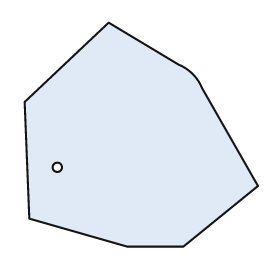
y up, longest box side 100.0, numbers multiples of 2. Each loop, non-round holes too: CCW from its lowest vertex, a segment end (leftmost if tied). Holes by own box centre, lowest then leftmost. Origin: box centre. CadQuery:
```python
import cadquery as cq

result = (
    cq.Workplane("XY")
    .moveTo(-6.0, -48.0)
    .lineTo(18.0, -48.0)
    .lineTo(50.0, -22.0)
    .lineTo(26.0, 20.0)
    .threePointArc((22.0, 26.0), (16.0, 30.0))
    .lineTo(-14.0, 48.0)
    .lineTo(-50.0, 14.0)
    .lineTo(-48.0, -36.0)
    .close()
    .moveTo(-36.0, -14.0)
    .circle(2.0)
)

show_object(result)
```